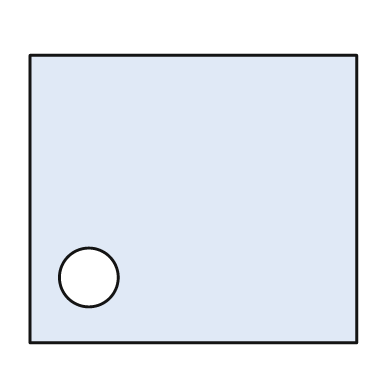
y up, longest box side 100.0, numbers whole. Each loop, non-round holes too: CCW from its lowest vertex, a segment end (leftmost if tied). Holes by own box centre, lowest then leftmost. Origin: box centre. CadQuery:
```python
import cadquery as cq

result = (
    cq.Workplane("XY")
    .moveTo(-50.0, -44.0)
    .lineTo(50.0, -44.0)
    .lineTo(50.0, 44.0)
    .lineTo(-50.0, 44.0)
    .close()
    .moveTo(-32.0, -24.0)
    .circle(9.0)
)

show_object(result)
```